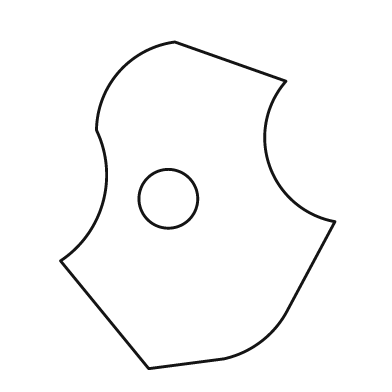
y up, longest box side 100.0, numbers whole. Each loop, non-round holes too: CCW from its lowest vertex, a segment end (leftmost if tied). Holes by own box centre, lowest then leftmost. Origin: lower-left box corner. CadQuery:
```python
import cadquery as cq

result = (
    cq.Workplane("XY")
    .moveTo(27.0, 0.0)
    .lineTo(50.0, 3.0)
    .threePointArc((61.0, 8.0), (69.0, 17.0))
    .lineTo(84.0, 45.0)
    .threePointArc((64.0, 62.0), (69.0, 88.0))
    .lineTo(35.0, 100.0)
    .threePointArc((18.0, 91.0), (11.0, 73.0))
    .threePointArc((13.0, 51.0), (0.0, 33.0))
    .close()
    .moveTo(33.0, 52.0)
    .circle(9.0)
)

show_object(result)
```